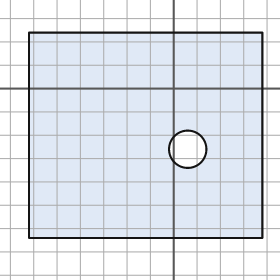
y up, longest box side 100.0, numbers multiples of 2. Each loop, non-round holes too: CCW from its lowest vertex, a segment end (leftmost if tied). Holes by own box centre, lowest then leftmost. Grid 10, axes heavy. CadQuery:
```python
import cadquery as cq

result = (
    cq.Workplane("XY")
    .moveTo(-62.0, -64.0)
    .lineTo(38.0, -64.0)
    .lineTo(38.0, 24.0)
    .lineTo(-62.0, 24.0)
    .close()
    .moveTo(6.0, -26.0)
    .circle(8.0)
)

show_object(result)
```